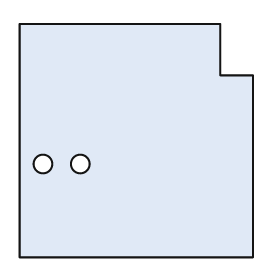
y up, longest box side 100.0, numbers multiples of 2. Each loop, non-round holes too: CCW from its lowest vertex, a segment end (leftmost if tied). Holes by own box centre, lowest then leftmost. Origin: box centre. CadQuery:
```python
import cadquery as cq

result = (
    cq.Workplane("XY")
    .moveTo(-50.0, -50.0)
    .lineTo(50.0, -50.0)
    .lineTo(50.0, 28.0)
    .lineTo(36.0, 28.0)
    .lineTo(36.0, 50.0)
    .lineTo(-50.0, 50.0)
    .close()
    .moveTo(-40.0, -10.0)
    .circle(4.0)
    .moveTo(-24.0, -10.0)
    .circle(4.0)
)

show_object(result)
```